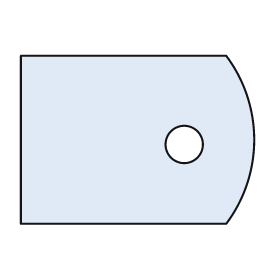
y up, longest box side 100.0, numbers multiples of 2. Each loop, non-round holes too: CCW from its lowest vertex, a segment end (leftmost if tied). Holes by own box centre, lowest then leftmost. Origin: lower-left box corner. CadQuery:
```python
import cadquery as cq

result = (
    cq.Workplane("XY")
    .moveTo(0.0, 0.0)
    .lineTo(88.0, 0.0)
    .threePointArc((100.0, 36.0), (88.0, 72.0))
    .lineTo(0.0, 72.0)
    .close()
    .moveTo(70.0, 34.0)
    .circle(8.0)
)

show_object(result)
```